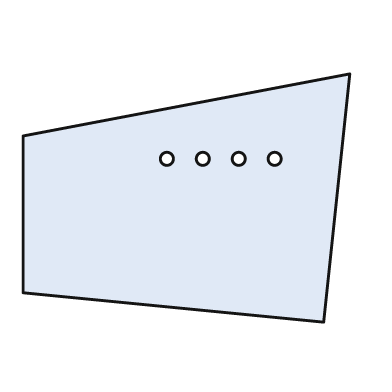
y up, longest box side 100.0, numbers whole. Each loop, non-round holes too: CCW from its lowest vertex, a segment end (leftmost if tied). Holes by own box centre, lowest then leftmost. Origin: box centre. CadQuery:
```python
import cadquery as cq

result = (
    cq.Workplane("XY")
    .moveTo(42.0, -38.0)
    .lineTo(50.0, 38.0)
    .lineTo(-50.0, 19.0)
    .lineTo(-50.0, -29.0)
    .close()
    .moveTo(-6.0, 12.0)
    .circle(2.0)
    .moveTo(5.0, 12.0)
    .circle(2.0)
    .moveTo(16.0, 12.0)
    .circle(2.0)
    .moveTo(27.0, 12.0)
    .circle(2.0)
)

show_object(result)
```